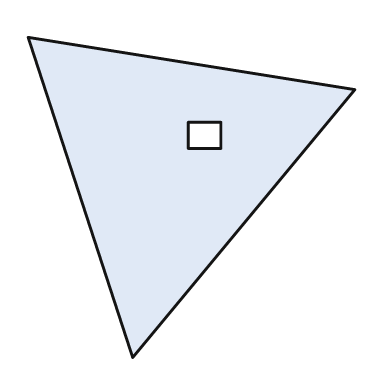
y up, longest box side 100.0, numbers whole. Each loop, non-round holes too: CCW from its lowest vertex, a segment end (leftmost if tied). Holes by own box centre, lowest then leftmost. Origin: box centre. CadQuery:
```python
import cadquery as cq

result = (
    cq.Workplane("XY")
    .moveTo(-18.0, -49.0)
    .lineTo(50.0, 33.0)
    .lineTo(-50.0, 49.0)
    .close()
    .moveTo(-1.0, 15.0)
    .lineTo(9.0, 15.0)
    .lineTo(9.0, 23.0)
    .lineTo(-1.0, 23.0)
    .close()
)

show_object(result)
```